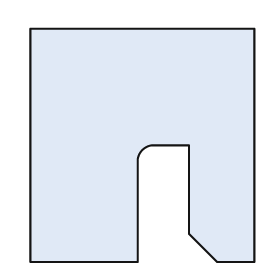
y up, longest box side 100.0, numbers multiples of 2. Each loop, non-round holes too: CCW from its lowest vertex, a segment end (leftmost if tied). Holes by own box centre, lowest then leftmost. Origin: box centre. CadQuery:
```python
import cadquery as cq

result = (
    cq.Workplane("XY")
    .moveTo(-48.0, -50.0)
    .lineTo(-2.0, -50.0)
    .lineTo(-2.0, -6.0)
    .threePointArc((0.0, -2.0), (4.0, 0.0))
    .lineTo(20.0, 0.0)
    .lineTo(20.0, -38.0)
    .lineTo(32.0, -50.0)
    .lineTo(48.0, -50.0)
    .lineTo(48.0, 50.0)
    .lineTo(-48.0, 50.0)
    .close()
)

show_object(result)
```